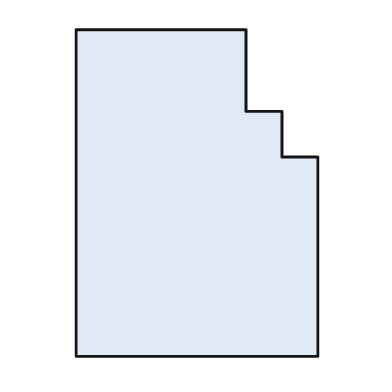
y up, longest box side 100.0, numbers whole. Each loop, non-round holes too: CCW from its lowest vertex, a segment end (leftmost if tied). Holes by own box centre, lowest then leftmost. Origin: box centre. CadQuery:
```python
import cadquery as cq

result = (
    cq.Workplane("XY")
    .moveTo(-37.0, -50.0)
    .lineTo(37.0, -50.0)
    .lineTo(37.0, 11.0)
    .lineTo(26.0, 11.0)
    .lineTo(26.0, 25.0)
    .lineTo(15.0, 25.0)
    .lineTo(15.0, 50.0)
    .lineTo(-37.0, 50.0)
    .close()
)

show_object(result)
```